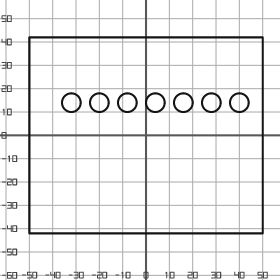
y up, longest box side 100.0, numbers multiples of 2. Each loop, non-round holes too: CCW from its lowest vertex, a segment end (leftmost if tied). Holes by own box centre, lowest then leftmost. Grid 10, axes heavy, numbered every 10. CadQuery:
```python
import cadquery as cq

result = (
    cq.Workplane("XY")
    .moveTo(-50.0, -42.0)
    .lineTo(50.0, -42.0)
    .lineTo(50.0, 42.0)
    .lineTo(-50.0, 42.0)
    .close()
    .moveTo(-32.0, 14.0)
    .circle(4.0)
    .moveTo(-20.0, 14.0)
    .circle(4.0)
    .moveTo(-8.0, 14.0)
    .circle(4.0)
    .moveTo(4.0, 14.0)
    .circle(4.0)
    .moveTo(16.0, 14.0)
    .circle(4.0)
    .moveTo(28.0, 14.0)
    .circle(4.0)
    .moveTo(40.0, 14.0)
    .circle(4.0)
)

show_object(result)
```